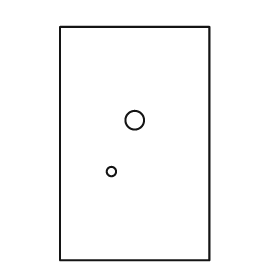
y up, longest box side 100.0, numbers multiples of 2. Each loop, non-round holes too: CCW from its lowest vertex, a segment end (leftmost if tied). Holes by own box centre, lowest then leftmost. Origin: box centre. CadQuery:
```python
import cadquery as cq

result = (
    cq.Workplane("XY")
    .moveTo(-32.0, -50.0)
    .lineTo(32.0, -50.0)
    .lineTo(32.0, 50.0)
    .lineTo(-32.0, 50.0)
    .close()
    .moveTo(-10.0, -12.0)
    .circle(2.0)
    .moveTo(0.0, 10.0)
    .circle(4.0)
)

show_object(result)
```